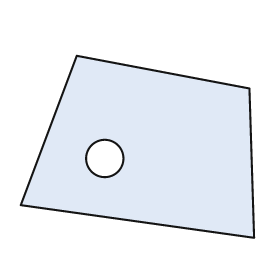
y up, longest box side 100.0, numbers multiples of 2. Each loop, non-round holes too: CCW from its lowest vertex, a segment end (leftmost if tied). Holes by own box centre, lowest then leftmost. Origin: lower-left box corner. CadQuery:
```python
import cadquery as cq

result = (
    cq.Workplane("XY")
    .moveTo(100.0, 0.0)
    .lineTo(98.0, 64.0)
    .lineTo(24.0, 78.0)
    .lineTo(0.0, 14.0)
    .close()
    .moveTo(36.0, 34.0)
    .circle(8.0)
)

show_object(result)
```